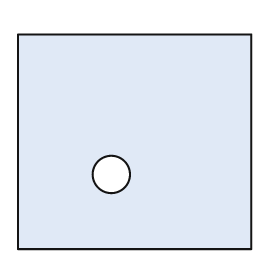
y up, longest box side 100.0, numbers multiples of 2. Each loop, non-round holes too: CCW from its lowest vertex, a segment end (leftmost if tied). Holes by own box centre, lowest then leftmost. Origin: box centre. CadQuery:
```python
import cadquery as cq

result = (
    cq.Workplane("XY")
    .moveTo(-50.0, -46.0)
    .lineTo(50.0, -46.0)
    .lineTo(50.0, 46.0)
    .lineTo(-50.0, 46.0)
    .close()
    .moveTo(-10.0, -14.0)
    .circle(8.0)
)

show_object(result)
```